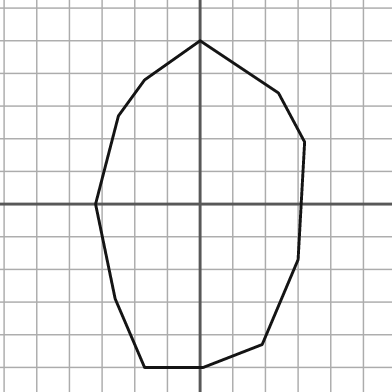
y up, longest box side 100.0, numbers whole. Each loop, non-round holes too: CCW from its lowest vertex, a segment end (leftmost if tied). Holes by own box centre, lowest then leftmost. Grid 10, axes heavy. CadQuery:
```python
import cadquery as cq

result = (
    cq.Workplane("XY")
    .moveTo(-17.0, -50.0)
    .lineTo(1.0, -50.0)
    .lineTo(19.0, -43.0)
    .lineTo(30.0, -17.0)
    .lineTo(32.0, 19.0)
    .lineTo(24.0, 34.0)
    .lineTo(0.0, 50.0)
    .lineTo(-17.0, 38.0)
    .lineTo(-25.0, 27.0)
    .lineTo(-32.0, 0.0)
    .lineTo(-26.0, -29.0)
    .close()
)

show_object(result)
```